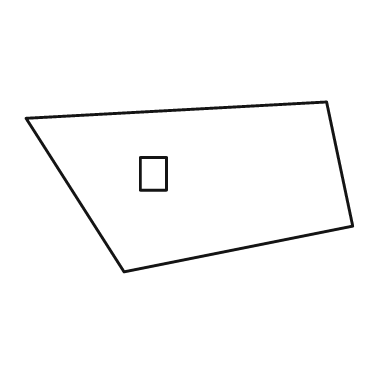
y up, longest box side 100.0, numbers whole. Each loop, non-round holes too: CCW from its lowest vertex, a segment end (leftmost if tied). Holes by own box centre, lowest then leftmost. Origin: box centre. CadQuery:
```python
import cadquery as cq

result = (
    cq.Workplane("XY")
    .moveTo(-20.0, -26.0)
    .lineTo(50.0, -12.0)
    .lineTo(42.0, 26.0)
    .lineTo(-50.0, 21.0)
    .close()
    .moveTo(-15.0, -1.0)
    .lineTo(-7.0, -1.0)
    .lineTo(-7.0, 9.0)
    .lineTo(-15.0, 9.0)
    .close()
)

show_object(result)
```